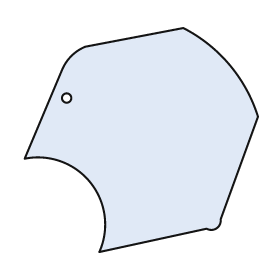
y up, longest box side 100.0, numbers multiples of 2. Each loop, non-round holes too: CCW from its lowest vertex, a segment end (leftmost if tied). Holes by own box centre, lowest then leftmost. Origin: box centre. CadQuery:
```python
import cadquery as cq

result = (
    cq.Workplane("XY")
    .moveTo(-18.0, -48.0)
    .lineTo(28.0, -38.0)
    .threePointArc((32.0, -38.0), (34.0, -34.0))
    .lineTo(50.0, 10.0)
    .threePointArc((38.0, 32.0), (18.0, 48.0))
    .lineTo(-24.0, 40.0)
    .threePointArc((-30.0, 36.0), (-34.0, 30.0))
    .lineTo(-50.0, -8.0)
    .threePointArc((-22.0, -18.0), (-18.0, -48.0))
    .close()
    .moveTo(-32.0, 18.0)
    .circle(2.0)
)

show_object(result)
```